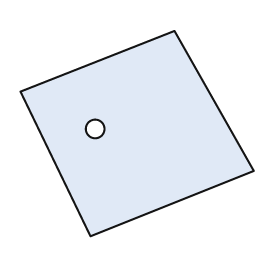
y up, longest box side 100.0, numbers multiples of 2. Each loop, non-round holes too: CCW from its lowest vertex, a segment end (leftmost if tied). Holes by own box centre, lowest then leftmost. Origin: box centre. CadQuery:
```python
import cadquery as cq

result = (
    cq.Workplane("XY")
    .moveTo(-20.0, -44.0)
    .lineTo(50.0, -16.0)
    .lineTo(16.0, 44.0)
    .lineTo(-50.0, 18.0)
    .close()
    .moveTo(-18.0, 2.0)
    .circle(4.0)
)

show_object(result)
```